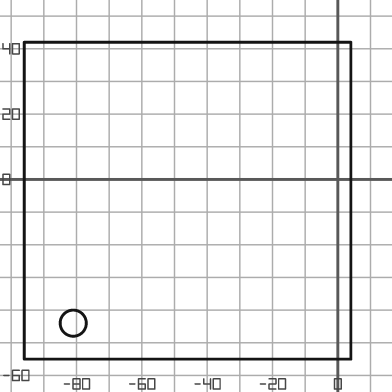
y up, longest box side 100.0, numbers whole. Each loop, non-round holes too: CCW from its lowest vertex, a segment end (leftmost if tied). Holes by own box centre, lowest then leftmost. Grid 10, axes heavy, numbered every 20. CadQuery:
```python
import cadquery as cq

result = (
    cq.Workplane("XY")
    .moveTo(-96.0, -55.0)
    .lineTo(4.0, -55.0)
    .lineTo(4.0, 42.0)
    .lineTo(-96.0, 42.0)
    .close()
    .moveTo(-81.0, -44.0)
    .circle(4.0)
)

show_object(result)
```